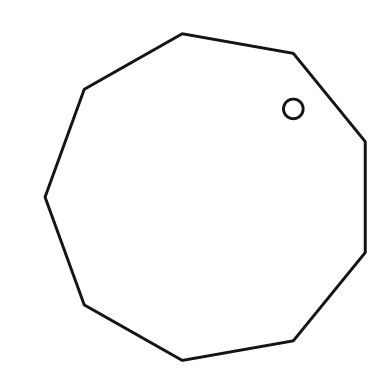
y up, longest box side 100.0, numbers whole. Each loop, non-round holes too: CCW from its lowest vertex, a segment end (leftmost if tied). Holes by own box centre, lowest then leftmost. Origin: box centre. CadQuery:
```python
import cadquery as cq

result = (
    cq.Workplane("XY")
    .moveTo(-7.0, -50.0)
    .lineTo(27.0, -44.0)
    .lineTo(49.0, -17.0)
    .lineTo(49.0, 17.0)
    .lineTo(27.0, 44.0)
    .lineTo(-7.0, 50.0)
    .lineTo(-37.0, 33.0)
    .lineTo(-49.0, 0.0)
    .lineTo(-37.0, -33.0)
    .close()
    .moveTo(27.0, 27.0)
    .circle(3.0)
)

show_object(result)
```